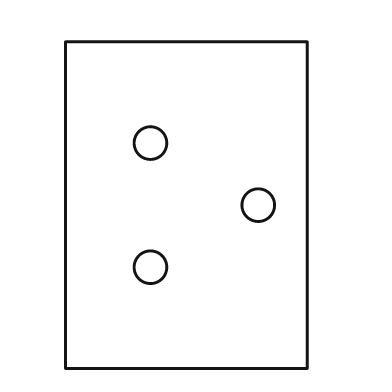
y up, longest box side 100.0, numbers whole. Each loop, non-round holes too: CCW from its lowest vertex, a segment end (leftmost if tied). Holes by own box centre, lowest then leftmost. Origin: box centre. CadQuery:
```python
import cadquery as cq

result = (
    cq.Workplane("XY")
    .moveTo(-37.0, -50.0)
    .lineTo(37.0, -50.0)
    .lineTo(37.0, 50.0)
    .lineTo(-37.0, 50.0)
    .close()
    .moveTo(-11.0, -19.0)
    .circle(5.0)
    .moveTo(22.0, 0.0)
    .circle(5.0)
    .moveTo(-11.0, 19.0)
    .circle(5.0)
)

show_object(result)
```